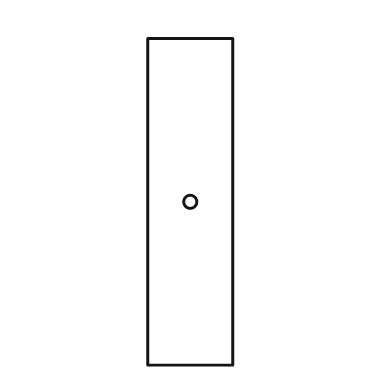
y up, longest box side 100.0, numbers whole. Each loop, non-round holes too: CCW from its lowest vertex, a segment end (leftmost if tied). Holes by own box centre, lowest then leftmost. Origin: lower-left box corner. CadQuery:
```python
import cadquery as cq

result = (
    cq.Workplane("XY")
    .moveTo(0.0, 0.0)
    .lineTo(26.0, 0.0)
    .lineTo(26.0, 100.0)
    .lineTo(0.0, 100.0)
    .close()
    .moveTo(13.0, 50.0)
    .circle(2.0)
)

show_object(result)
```